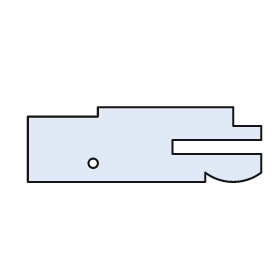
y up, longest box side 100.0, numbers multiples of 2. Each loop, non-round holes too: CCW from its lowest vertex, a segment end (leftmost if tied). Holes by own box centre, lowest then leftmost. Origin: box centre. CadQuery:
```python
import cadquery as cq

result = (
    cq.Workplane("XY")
    .moveTo(-50.0, -16.0)
    .lineTo(26.0, -16.0)
    .lineTo(26.0, -12.0)
    .threePointArc((38.0, -16.0), (50.0, -12.0))
    .lineTo(50.0, -4.0)
    .lineTo(12.0, -4.0)
    .lineTo(12.0, 2.0)
    .lineTo(50.0, 2.0)
    .lineTo(50.0, 8.0)
    .lineTo(38.0, 8.0)
    .lineTo(38.0, 16.0)
    .lineTo(-20.0, 16.0)
    .lineTo(-20.0, 12.0)
    .lineTo(-50.0, 12.0)
    .close()
    .moveTo(-22.0, -8.0)
    .circle(2.0)
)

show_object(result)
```